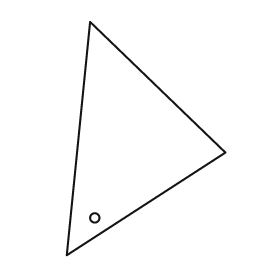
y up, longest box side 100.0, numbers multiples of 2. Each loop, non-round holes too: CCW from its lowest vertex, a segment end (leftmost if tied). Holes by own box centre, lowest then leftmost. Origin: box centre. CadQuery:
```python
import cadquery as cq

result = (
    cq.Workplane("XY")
    .moveTo(-34.0, -50.0)
    .lineTo(34.0, -6.0)
    .lineTo(-24.0, 50.0)
    .close()
    .moveTo(-22.0, -34.0)
    .circle(2.0)
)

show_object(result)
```